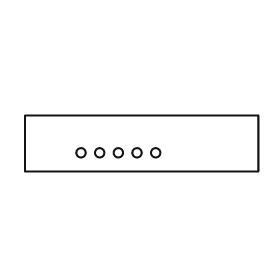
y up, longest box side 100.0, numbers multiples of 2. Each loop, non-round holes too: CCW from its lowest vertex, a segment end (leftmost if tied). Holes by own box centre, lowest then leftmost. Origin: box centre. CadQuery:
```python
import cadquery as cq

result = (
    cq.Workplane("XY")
    .moveTo(-50.0, -12.0)
    .lineTo(50.0, -12.0)
    .lineTo(50.0, 12.0)
    .lineTo(-50.0, 12.0)
    .close()
    .moveTo(-26.0, -4.0)
    .circle(2.0)
    .moveTo(-18.0, -4.0)
    .circle(2.0)
    .moveTo(-10.0, -4.0)
    .circle(2.0)
    .moveTo(-2.0, -4.0)
    .circle(2.0)
    .moveTo(6.0, -4.0)
    .circle(2.0)
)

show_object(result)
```